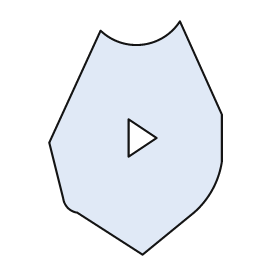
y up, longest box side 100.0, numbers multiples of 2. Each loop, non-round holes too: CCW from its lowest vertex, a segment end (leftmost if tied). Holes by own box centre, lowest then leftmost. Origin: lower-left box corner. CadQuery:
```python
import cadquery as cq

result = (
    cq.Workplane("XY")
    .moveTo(40.0, 0.0)
    .lineTo(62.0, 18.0)
    .threePointArc((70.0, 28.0), (74.0, 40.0))
    .lineTo(74.0, 60.0)
    .lineTo(56.0, 100.0)
    .threePointArc((40.0, 90.0), (22.0, 96.0))
    .lineTo(0.0, 48.0)
    .lineTo(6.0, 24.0)
    .threePointArc((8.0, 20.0), (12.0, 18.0))
    .close()
    .moveTo(34.0, 42.0)
    .lineTo(46.0, 50.0)
    .lineTo(34.0, 58.0)
    .close()
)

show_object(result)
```